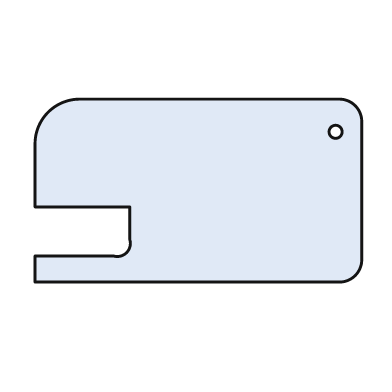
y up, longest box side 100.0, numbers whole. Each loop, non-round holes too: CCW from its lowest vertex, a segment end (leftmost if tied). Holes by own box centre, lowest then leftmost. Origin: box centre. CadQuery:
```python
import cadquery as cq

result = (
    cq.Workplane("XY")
    .moveTo(-50.0, -28.0)
    .lineTo(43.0, -28.0)
    .threePointArc((48.0, -26.0), (50.0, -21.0))
    .lineTo(50.0, 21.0)
    .threePointArc((48.0, 26.0), (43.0, 28.0))
    .lineTo(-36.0, 28.0)
    .threePointArc((-46.0, 24.0), (-50.0, 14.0))
    .lineTo(-50.0, -5.0)
    .lineTo(-21.0, -5.0)
    .lineTo(-21.0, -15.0)
    .threePointArc((-22.0, -19.0), (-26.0, -20.0))
    .lineTo(-50.0, -20.0)
    .close()
    .moveTo(42.0, 18.0)
    .circle(2.0)
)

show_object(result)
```